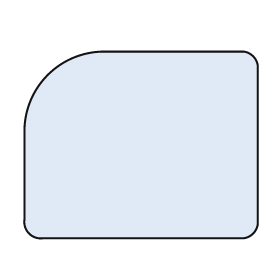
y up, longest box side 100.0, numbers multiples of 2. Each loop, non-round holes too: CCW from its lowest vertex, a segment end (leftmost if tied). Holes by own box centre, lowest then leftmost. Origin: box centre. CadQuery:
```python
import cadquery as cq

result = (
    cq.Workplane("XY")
    .moveTo(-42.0, -40.0)
    .lineTo(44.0, -40.0)
    .threePointArc((48.0, -38.0), (50.0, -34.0))
    .lineTo(50.0, 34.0)
    .threePointArc((48.0, 38.0), (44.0, 40.0))
    .lineTo(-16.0, 40.0)
    .threePointArc((-40.0, 30.0), (-50.0, 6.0))
    .lineTo(-50.0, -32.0)
    .threePointArc((-48.0, -38.0), (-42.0, -40.0))
    .close()
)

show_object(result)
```